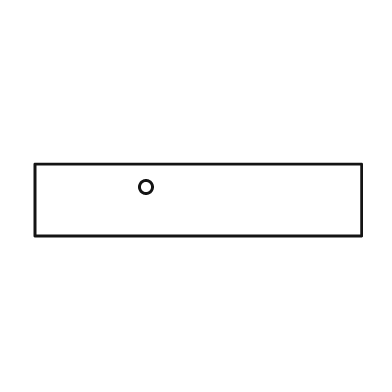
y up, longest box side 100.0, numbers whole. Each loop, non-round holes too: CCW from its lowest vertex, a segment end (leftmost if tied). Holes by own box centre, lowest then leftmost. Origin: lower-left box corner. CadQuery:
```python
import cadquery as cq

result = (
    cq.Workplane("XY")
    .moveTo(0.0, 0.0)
    .lineTo(100.0, 0.0)
    .lineTo(100.0, 22.0)
    .lineTo(0.0, 22.0)
    .close()
    .moveTo(34.0, 15.0)
    .circle(2.0)
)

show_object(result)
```